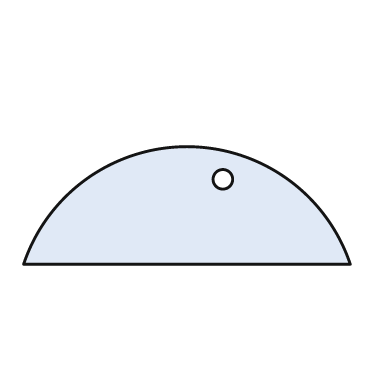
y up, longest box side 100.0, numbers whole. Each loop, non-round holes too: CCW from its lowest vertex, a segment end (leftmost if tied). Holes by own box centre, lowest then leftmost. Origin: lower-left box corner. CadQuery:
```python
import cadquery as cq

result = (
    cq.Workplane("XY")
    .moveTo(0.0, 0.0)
    .lineTo(100.0, 0.0)
    .threePointArc((50.0, 36.0), (0.0, 0.0))
    .close()
    .moveTo(61.0, 26.0)
    .circle(3.0)
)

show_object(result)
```